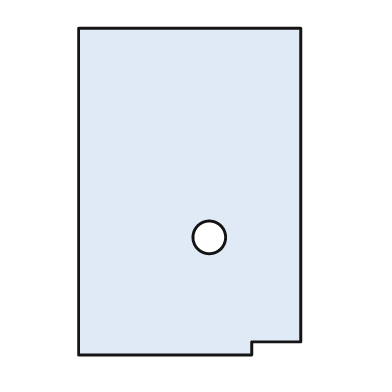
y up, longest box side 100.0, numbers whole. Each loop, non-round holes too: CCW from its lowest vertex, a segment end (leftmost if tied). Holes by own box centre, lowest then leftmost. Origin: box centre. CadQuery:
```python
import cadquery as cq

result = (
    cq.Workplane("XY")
    .moveTo(-34.0, -50.0)
    .lineTo(19.0, -50.0)
    .lineTo(19.0, -46.0)
    .lineTo(34.0, -46.0)
    .lineTo(34.0, 50.0)
    .lineTo(-34.0, 50.0)
    .close()
    .moveTo(6.0, -14.0)
    .circle(5.0)
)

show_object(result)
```